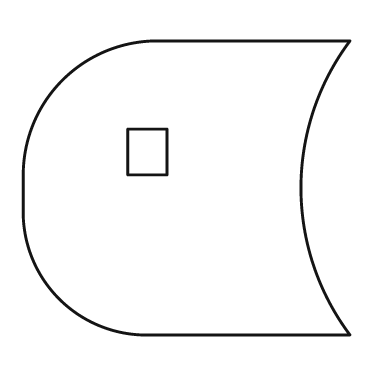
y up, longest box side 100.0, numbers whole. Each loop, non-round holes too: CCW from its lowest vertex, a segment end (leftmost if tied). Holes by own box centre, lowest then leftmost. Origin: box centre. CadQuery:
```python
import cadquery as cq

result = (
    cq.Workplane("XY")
    .moveTo(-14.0, -45.0)
    .lineTo(50.0, -45.0)
    .threePointArc((35.0, 0.0), (50.0, 45.0))
    .lineTo(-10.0, 45.0)
    .threePointArc((-38.0, 33.0), (-50.0, 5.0))
    .lineTo(-50.0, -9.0)
    .threePointArc((-39.0, -34.0), (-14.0, -45.0))
    .close()
    .moveTo(-18.0, 4.0)
    .lineTo(-6.0, 4.0)
    .lineTo(-6.0, 18.0)
    .lineTo(-18.0, 18.0)
    .close()
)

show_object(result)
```